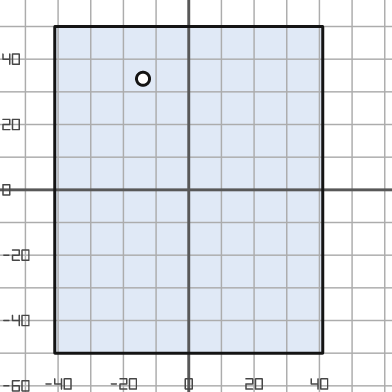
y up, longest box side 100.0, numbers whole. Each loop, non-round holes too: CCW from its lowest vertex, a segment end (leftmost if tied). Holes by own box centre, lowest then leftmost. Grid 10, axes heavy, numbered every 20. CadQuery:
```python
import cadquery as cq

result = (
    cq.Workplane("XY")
    .moveTo(-41.0, -50.0)
    .lineTo(41.0, -50.0)
    .lineTo(41.0, 50.0)
    .lineTo(-41.0, 50.0)
    .close()
    .moveTo(-14.0, 34.0)
    .circle(2.0)
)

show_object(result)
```